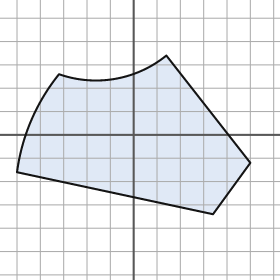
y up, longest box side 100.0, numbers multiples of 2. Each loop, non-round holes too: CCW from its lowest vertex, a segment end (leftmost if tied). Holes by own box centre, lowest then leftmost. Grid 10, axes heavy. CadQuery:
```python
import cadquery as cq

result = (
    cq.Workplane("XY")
    .moveTo(34.0, -34.0)
    .lineTo(50.0, -12.0)
    .lineTo(14.0, 34.0)
    .threePointArc((-8.0, 24.0), (-32.0, 26.0))
    .threePointArc((-44.0, 6.0), (-50.0, -16.0))
    .close()
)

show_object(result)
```